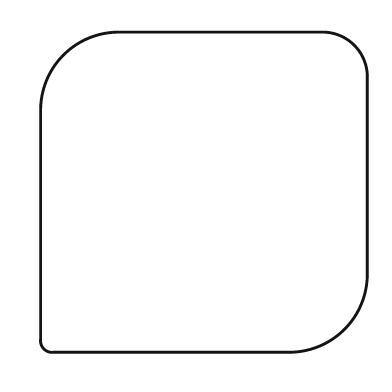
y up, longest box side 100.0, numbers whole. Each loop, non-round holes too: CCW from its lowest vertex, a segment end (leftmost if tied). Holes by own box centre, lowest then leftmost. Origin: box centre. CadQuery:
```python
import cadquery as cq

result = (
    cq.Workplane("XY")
    .moveTo(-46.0, -49.0)
    .lineTo(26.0, -49.0)
    .threePointArc((43.0, -42.0), (50.0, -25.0))
    .lineTo(50.0, 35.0)
    .threePointArc((46.0, 45.0), (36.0, 49.0))
    .lineTo(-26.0, 49.0)
    .threePointArc((-43.0, 42.0), (-50.0, 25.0))
    .lineTo(-50.0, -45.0)
    .threePointArc((-49.0, -48.0), (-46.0, -49.0))
    .close()
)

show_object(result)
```